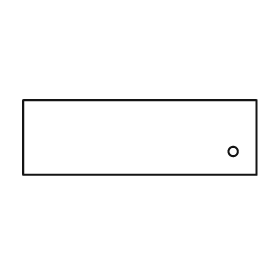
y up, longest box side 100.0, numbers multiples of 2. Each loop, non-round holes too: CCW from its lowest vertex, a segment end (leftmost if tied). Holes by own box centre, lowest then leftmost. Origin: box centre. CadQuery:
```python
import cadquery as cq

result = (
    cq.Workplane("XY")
    .moveTo(-50.0, -16.0)
    .lineTo(50.0, -16.0)
    .lineTo(50.0, 16.0)
    .lineTo(-50.0, 16.0)
    .close()
    .moveTo(40.0, -6.0)
    .circle(2.0)
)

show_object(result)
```